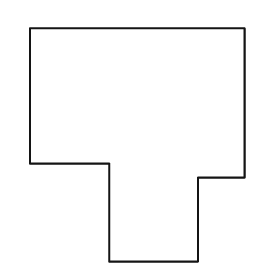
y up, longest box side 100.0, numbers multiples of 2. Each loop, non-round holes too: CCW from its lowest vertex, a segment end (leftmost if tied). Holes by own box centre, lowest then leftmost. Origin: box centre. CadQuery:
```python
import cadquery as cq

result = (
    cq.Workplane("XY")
    .moveTo(-12.0, -50.0)
    .lineTo(26.0, -50.0)
    .lineTo(26.0, -14.0)
    .lineTo(46.0, -14.0)
    .lineTo(46.0, 50.0)
    .lineTo(-46.0, 50.0)
    .lineTo(-46.0, -8.0)
    .lineTo(-12.0, -8.0)
    .close()
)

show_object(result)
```